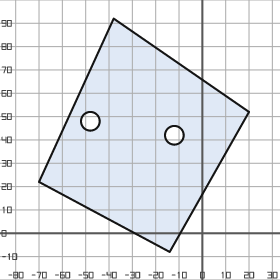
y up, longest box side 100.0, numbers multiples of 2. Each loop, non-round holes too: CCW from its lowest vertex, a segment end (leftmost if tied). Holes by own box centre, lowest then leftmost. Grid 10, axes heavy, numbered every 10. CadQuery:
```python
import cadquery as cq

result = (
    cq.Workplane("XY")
    .moveTo(-14.0, -8.0)
    .lineTo(20.0, 52.0)
    .lineTo(-38.0, 92.0)
    .lineTo(-70.0, 22.0)
    .close()
    .moveTo(-12.0, 42.0)
    .circle(4.0)
    .moveTo(-48.0, 48.0)
    .circle(4.0)
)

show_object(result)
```